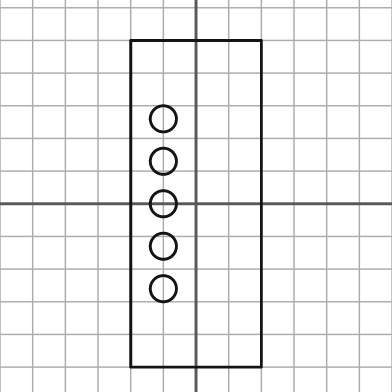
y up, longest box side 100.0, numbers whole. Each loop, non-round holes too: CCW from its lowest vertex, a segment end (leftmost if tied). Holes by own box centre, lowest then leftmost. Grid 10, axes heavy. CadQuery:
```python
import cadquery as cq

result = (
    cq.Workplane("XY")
    .moveTo(-20.0, -50.0)
    .lineTo(20.0, -50.0)
    .lineTo(20.0, 50.0)
    .lineTo(-20.0, 50.0)
    .close()
    .moveTo(-10.0, -26.0)
    .circle(4.0)
    .moveTo(-10.0, -13.0)
    .circle(4.0)
    .moveTo(-10.0, 0.0)
    .circle(4.0)
    .moveTo(-10.0, 13.0)
    .circle(4.0)
    .moveTo(-10.0, 26.0)
    .circle(4.0)
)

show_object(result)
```